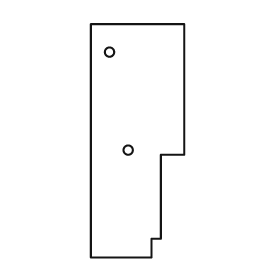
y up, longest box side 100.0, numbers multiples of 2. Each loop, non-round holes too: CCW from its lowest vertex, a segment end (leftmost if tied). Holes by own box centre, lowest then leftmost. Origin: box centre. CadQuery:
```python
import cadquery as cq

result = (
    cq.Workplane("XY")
    .moveTo(-20.0, -50.0)
    .lineTo(6.0, -50.0)
    .lineTo(6.0, -42.0)
    .lineTo(10.0, -42.0)
    .lineTo(10.0, -6.0)
    .lineTo(20.0, -6.0)
    .lineTo(20.0, 50.0)
    .lineTo(-20.0, 50.0)
    .close()
    .moveTo(-4.0, -4.0)
    .circle(2.0)
    .moveTo(-12.0, 38.0)
    .circle(2.0)
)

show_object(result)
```